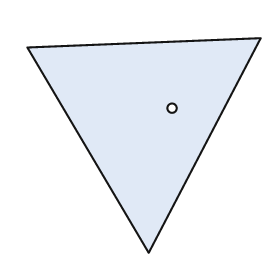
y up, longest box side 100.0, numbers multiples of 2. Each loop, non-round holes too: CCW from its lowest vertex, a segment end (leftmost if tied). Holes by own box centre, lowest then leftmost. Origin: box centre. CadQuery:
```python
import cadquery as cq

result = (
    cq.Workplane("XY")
    .moveTo(2.0, -46.0)
    .lineTo(50.0, 46.0)
    .lineTo(-50.0, 42.0)
    .close()
    .moveTo(12.0, 16.0)
    .circle(2.0)
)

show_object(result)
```